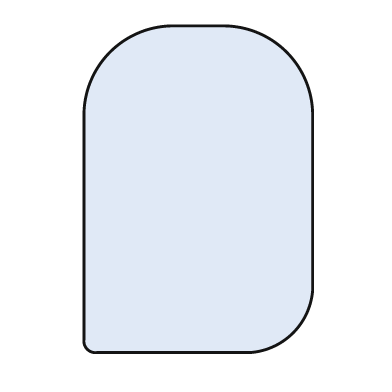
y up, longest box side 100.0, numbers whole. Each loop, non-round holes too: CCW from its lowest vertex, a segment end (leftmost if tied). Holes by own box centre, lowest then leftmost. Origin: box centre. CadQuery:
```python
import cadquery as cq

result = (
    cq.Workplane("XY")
    .moveTo(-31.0, -50.0)
    .lineTo(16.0, -50.0)
    .threePointArc((29.0, -44.0), (35.0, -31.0))
    .lineTo(35.0, 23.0)
    .threePointArc((27.0, 42.0), (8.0, 50.0))
    .lineTo(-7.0, 50.0)
    .threePointArc((-27.0, 42.0), (-35.0, 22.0))
    .lineTo(-35.0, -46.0)
    .threePointArc((-34.0, -49.0), (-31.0, -50.0))
    .close()
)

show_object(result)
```